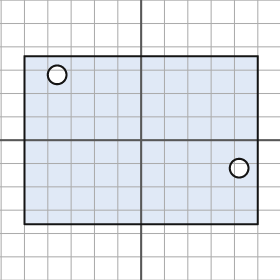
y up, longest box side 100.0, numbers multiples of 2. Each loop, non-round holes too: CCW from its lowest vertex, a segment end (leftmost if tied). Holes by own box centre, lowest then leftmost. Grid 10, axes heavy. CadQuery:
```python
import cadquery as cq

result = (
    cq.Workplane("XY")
    .moveTo(-50.0, -36.0)
    .lineTo(50.0, -36.0)
    .lineTo(50.0, 36.0)
    .lineTo(-50.0, 36.0)
    .close()
    .moveTo(42.0, -12.0)
    .circle(4.0)
    .moveTo(-36.0, 28.0)
    .circle(4.0)
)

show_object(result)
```